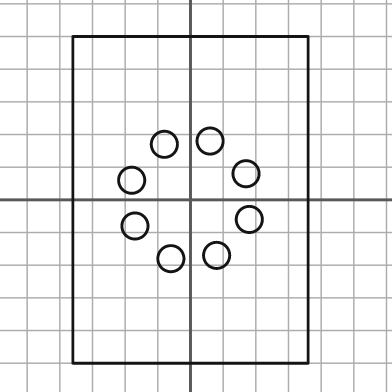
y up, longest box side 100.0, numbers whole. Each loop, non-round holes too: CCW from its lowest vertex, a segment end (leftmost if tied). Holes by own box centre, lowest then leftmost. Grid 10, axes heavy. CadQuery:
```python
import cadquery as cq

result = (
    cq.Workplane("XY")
    .moveTo(-36.0, -50.0)
    .lineTo(36.0, -50.0)
    .lineTo(36.0, 50.0)
    .lineTo(-36.0, 50.0)
    .close()
    .moveTo(-6.0, -18.0)
    .circle(4.0)
    .moveTo(8.0, -17.0)
    .circle(4.0)
    .moveTo(-17.0, -8.0)
    .circle(4.0)
    .moveTo(18.0, -6.0)
    .circle(4.0)
    .moveTo(-18.0, 6.0)
    .circle(4.0)
    .moveTo(17.0, 8.0)
    .circle(4.0)
    .moveTo(-8.0, 17.0)
    .circle(4.0)
    .moveTo(6.0, 18.0)
    .circle(4.0)
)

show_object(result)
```